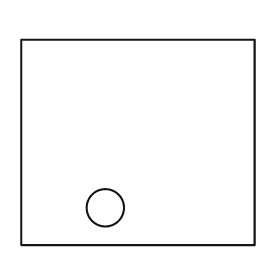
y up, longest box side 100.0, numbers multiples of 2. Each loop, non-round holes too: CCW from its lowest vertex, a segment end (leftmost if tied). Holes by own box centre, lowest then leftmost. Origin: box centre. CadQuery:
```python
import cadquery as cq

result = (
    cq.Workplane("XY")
    .moveTo(-50.0, -44.0)
    .lineTo(50.0, -44.0)
    .lineTo(50.0, 44.0)
    .lineTo(-50.0, 44.0)
    .close()
    .moveTo(-14.0, -28.0)
    .circle(8.0)
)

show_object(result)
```